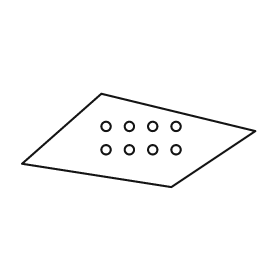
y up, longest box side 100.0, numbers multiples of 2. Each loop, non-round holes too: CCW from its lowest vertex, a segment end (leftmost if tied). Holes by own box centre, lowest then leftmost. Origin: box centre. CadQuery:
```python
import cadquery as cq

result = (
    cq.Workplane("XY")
    .moveTo(14.0, -20.0)
    .lineTo(50.0, 4.0)
    .lineTo(-16.0, 20.0)
    .lineTo(-50.0, -10.0)
    .close()
    .moveTo(-14.0, -4.0)
    .circle(2.0)
    .moveTo(-4.0, -4.0)
    .circle(2.0)
    .moveTo(6.0, -4.0)
    .circle(2.0)
    .moveTo(16.0, -4.0)
    .circle(2.0)
    .moveTo(-14.0, 6.0)
    .circle(2.0)
    .moveTo(-4.0, 6.0)
    .circle(2.0)
    .moveTo(6.0, 6.0)
    .circle(2.0)
    .moveTo(16.0, 6.0)
    .circle(2.0)
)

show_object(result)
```